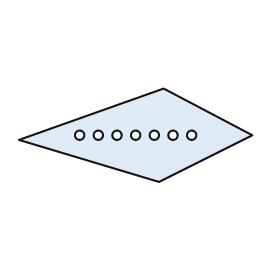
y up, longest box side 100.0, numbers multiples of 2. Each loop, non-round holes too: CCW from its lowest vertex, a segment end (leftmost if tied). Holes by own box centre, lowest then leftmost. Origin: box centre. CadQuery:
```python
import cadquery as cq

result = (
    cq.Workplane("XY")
    .moveTo(10.0, -20.0)
    .lineTo(50.0, 0.0)
    .lineTo(12.0, 20.0)
    .lineTo(-50.0, -2.0)
    .close()
    .moveTo(-24.0, 0.0)
    .circle(2.0)
    .moveTo(-16.0, 0.0)
    .circle(2.0)
    .moveTo(-8.0, 0.0)
    .circle(2.0)
    .moveTo(0.0, 0.0)
    .circle(2.0)
    .moveTo(8.0, 0.0)
    .circle(2.0)
    .moveTo(16.0, 0.0)
    .circle(2.0)
    .moveTo(24.0, 0.0)
    .circle(2.0)
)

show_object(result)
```